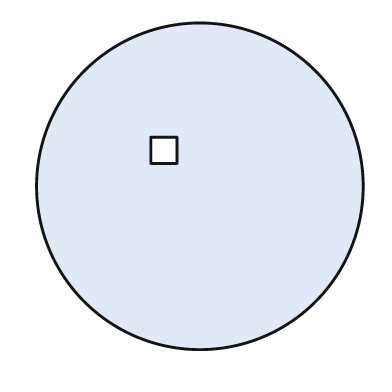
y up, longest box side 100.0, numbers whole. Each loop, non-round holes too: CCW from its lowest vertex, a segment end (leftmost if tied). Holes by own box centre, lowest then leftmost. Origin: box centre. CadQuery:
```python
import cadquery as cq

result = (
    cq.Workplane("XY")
    .moveTo(0.0, 0.0)
    .circle(50.0)
    .moveTo(-15.0, 7.0)
    .lineTo(-7.0, 7.0)
    .lineTo(-7.0, 15.0)
    .lineTo(-15.0, 15.0)
    .close()
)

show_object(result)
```